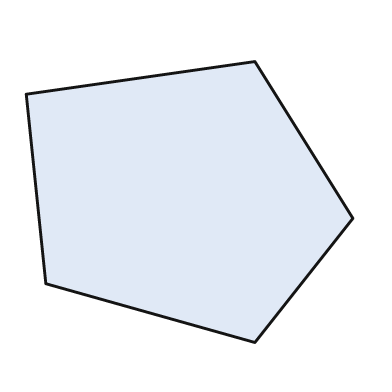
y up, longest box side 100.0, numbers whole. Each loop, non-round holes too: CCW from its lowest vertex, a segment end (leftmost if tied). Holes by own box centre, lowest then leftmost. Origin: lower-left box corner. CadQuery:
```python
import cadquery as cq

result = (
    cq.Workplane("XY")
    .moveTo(70.0, 0.0)
    .lineTo(100.0, 38.0)
    .lineTo(70.0, 86.0)
    .lineTo(0.0, 76.0)
    .lineTo(6.0, 18.0)
    .close()
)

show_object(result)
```